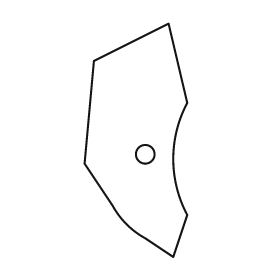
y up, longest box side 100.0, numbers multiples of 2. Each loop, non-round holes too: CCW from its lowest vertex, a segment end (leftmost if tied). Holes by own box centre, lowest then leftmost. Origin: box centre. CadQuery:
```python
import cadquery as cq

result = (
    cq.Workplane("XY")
    .moveTo(16.0, -50.0)
    .lineTo(22.0, -32.0)
    .threePointArc((16.0, -8.0), (22.0, 16.0))
    .lineTo(14.0, 50.0)
    .lineTo(-18.0, 34.0)
    .lineTo(-22.0, -10.0)
    .lineTo(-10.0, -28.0)
    .threePointArc((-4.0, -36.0), (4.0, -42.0))
    .close()
    .moveTo(4.0, -6.0)
    .circle(4.0)
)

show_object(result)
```